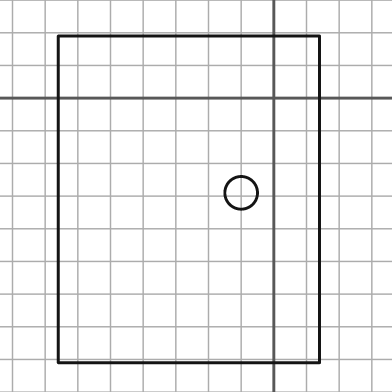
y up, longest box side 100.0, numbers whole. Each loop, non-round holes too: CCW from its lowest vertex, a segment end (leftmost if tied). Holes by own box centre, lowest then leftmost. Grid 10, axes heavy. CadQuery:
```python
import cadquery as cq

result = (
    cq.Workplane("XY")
    .moveTo(-66.0, -81.0)
    .lineTo(14.0, -81.0)
    .lineTo(14.0, 19.0)
    .lineTo(-66.0, 19.0)
    .close()
    .moveTo(-10.0, -29.0)
    .circle(5.0)
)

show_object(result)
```